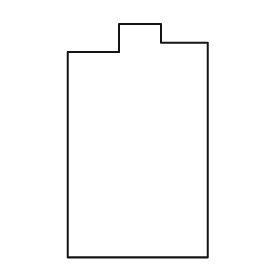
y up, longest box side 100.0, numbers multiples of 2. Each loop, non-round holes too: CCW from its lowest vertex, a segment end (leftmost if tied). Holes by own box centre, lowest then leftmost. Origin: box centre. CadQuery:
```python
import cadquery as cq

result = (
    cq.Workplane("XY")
    .moveTo(-30.0, -50.0)
    .lineTo(30.0, -50.0)
    .lineTo(30.0, 42.0)
    .lineTo(10.0, 42.0)
    .lineTo(10.0, 50.0)
    .lineTo(-8.0, 50.0)
    .lineTo(-8.0, 38.0)
    .lineTo(-30.0, 38.0)
    .close()
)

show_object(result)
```